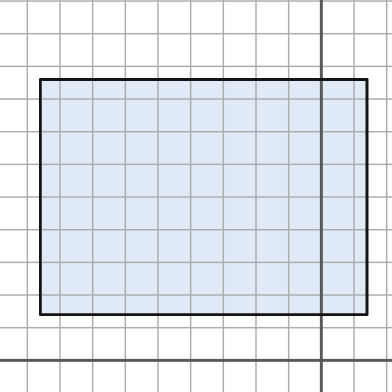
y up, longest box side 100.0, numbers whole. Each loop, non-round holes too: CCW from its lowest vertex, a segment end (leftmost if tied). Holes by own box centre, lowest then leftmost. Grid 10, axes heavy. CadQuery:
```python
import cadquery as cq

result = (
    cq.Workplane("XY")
    .moveTo(-86.0, 14.0)
    .lineTo(14.0, 14.0)
    .lineTo(14.0, 86.0)
    .lineTo(-86.0, 86.0)
    .close()
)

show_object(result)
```